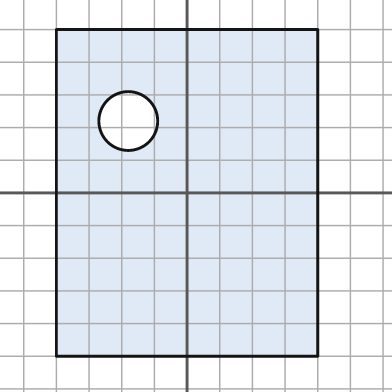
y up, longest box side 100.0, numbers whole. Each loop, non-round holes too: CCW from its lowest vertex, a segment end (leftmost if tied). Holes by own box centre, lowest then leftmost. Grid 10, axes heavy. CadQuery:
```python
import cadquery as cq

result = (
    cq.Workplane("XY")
    .moveTo(-40.0, -50.0)
    .lineTo(40.0, -50.0)
    .lineTo(40.0, 50.0)
    .lineTo(-40.0, 50.0)
    .close()
    .moveTo(-18.0, 22.0)
    .circle(9.0)
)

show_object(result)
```